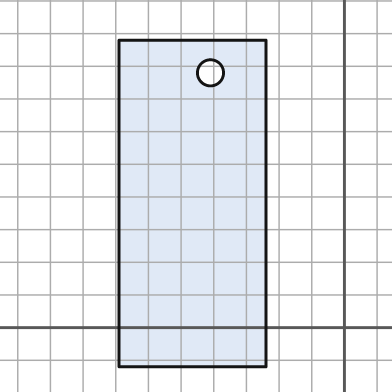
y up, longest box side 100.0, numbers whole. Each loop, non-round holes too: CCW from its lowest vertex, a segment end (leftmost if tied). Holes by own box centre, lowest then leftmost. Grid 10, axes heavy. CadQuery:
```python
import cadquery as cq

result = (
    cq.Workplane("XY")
    .moveTo(-69.0, -12.0)
    .lineTo(-24.0, -12.0)
    .lineTo(-24.0, 88.0)
    .lineTo(-69.0, 88.0)
    .close()
    .moveTo(-41.0, 78.0)
    .circle(4.0)
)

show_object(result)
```